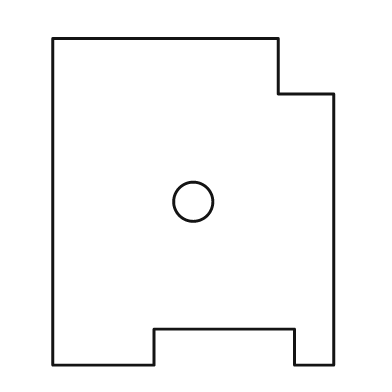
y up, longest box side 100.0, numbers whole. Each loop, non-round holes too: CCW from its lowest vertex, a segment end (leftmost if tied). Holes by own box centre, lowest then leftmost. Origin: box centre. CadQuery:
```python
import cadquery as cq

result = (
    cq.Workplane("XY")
    .moveTo(-43.0, -50.0)
    .lineTo(-12.0, -50.0)
    .lineTo(-12.0, -39.0)
    .lineTo(31.0, -39.0)
    .lineTo(31.0, -50.0)
    .lineTo(43.0, -50.0)
    .lineTo(43.0, 33.0)
    .lineTo(26.0, 33.0)
    .lineTo(26.0, 50.0)
    .lineTo(-43.0, 50.0)
    .close()
    .moveTo(0.0, 0.0)
    .circle(6.0)
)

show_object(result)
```